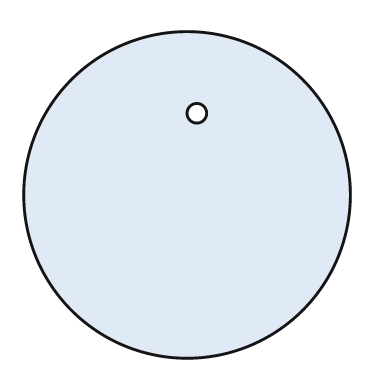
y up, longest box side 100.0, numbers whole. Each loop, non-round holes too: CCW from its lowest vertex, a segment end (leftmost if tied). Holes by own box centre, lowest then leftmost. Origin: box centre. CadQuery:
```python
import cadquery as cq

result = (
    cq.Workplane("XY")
    .moveTo(0.0, 0.0)
    .circle(50.0)
    .moveTo(3.0, 25.0)
    .circle(3.0)
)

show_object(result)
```